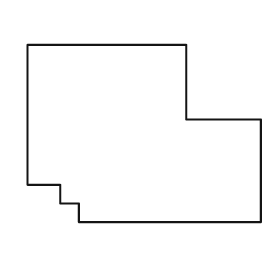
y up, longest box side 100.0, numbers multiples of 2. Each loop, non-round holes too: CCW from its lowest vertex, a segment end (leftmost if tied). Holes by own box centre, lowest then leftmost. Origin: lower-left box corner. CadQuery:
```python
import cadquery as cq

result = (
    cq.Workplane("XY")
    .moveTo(22.0, 0.0)
    .lineTo(100.0, 0.0)
    .lineTo(100.0, 44.0)
    .lineTo(68.0, 44.0)
    .lineTo(68.0, 76.0)
    .lineTo(0.0, 76.0)
    .lineTo(0.0, 16.0)
    .lineTo(14.0, 16.0)
    .lineTo(14.0, 8.0)
    .lineTo(22.0, 8.0)
    .close()
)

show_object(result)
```